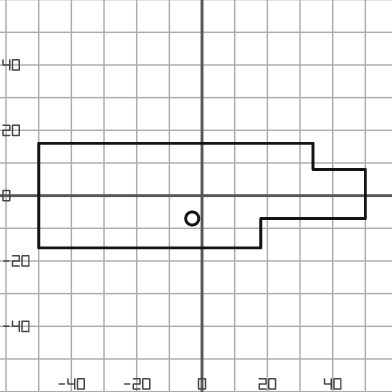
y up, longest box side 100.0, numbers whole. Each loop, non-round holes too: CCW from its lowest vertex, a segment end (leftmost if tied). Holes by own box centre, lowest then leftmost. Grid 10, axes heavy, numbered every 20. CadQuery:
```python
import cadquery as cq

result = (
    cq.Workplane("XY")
    .moveTo(-50.0, -16.0)
    .lineTo(18.0, -16.0)
    .lineTo(18.0, -7.0)
    .lineTo(50.0, -7.0)
    .lineTo(50.0, 8.0)
    .lineTo(34.0, 8.0)
    .lineTo(34.0, 16.0)
    .lineTo(-50.0, 16.0)
    .close()
    .moveTo(-3.0, -7.0)
    .circle(2.0)
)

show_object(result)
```